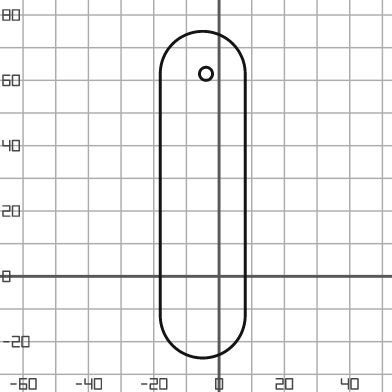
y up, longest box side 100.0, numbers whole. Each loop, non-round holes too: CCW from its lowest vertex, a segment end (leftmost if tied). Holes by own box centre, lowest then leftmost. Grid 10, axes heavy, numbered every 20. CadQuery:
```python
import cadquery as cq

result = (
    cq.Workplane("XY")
    .moveTo(-18.0, -12.0)
    .threePointArc((-5.0, -25.0), (8.0, -12.0))
    .lineTo(8.0, 62.0)
    .threePointArc((-5.0, 75.0), (-18.0, 62.0))
    .close()
    .moveTo(-4.0, 62.0)
    .circle(2.0)
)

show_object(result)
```